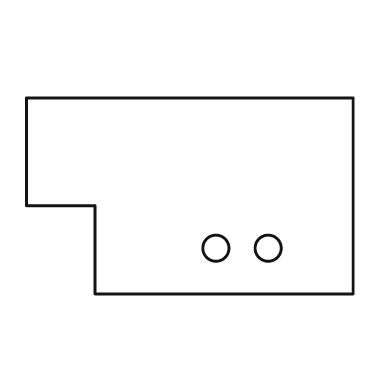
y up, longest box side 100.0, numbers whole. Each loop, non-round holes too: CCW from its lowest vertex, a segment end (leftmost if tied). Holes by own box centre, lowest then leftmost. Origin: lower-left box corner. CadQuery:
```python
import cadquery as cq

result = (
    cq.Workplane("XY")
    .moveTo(21.0, 0.0)
    .lineTo(100.0, 0.0)
    .lineTo(100.0, 60.0)
    .lineTo(0.0, 60.0)
    .lineTo(0.0, 27.0)
    .lineTo(21.0, 27.0)
    .close()
    .moveTo(58.0, 14.0)
    .circle(4.0)
    .moveTo(74.0, 14.0)
    .circle(4.0)
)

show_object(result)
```